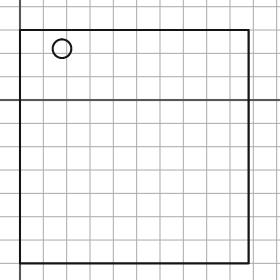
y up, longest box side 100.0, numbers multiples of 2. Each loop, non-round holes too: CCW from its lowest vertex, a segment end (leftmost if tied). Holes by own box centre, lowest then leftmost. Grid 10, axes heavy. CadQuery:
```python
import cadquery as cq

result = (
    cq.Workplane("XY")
    .moveTo(0.0, -70.0)
    .lineTo(98.0, -70.0)
    .lineTo(98.0, 30.0)
    .lineTo(0.0, 30.0)
    .close()
    .moveTo(18.0, 22.0)
    .circle(4.0)
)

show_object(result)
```